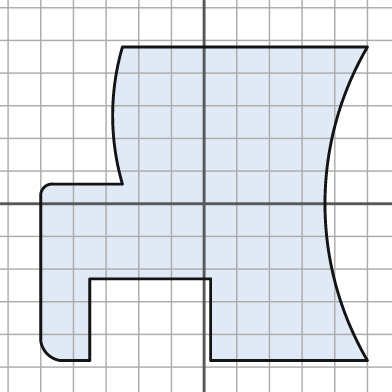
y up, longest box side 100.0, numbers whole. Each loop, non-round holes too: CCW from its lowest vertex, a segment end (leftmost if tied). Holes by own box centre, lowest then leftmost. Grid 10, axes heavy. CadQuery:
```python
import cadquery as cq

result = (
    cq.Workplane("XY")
    .moveTo(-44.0, -48.0)
    .lineTo(-35.0, -48.0)
    .lineTo(-35.0, -23.0)
    .lineTo(2.0, -23.0)
    .lineTo(2.0, -48.0)
    .lineTo(50.0, -48.0)
    .threePointArc((37.0, 0.0), (50.0, 48.0))
    .lineTo(-25.0, 48.0)
    .threePointArc((-28.0, 27.0), (-25.0, 6.0))
    .lineTo(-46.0, 6.0)
    .threePointArc((-49.0, 5.0), (-50.0, 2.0))
    .lineTo(-50.0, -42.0)
    .threePointArc((-48.0, -46.0), (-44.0, -48.0))
    .close()
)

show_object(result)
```